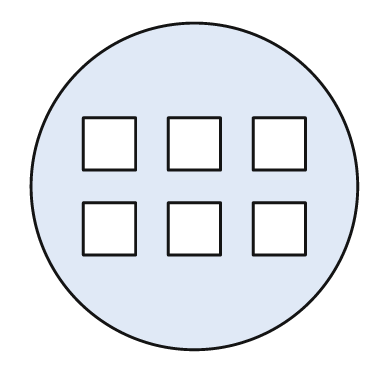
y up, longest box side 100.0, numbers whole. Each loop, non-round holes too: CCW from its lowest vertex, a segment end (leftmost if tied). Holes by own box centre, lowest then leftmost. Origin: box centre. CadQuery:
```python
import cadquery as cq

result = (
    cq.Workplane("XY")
    .moveTo(0.0, 0.0)
    .circle(50.0)
    .moveTo(-34.0, -21.0)
    .lineTo(-18.0, -21.0)
    .lineTo(-18.0, -5.0)
    .lineTo(-34.0, -5.0)
    .close()
    .moveTo(-8.0, -21.0)
    .lineTo(8.0, -21.0)
    .lineTo(8.0, -5.0)
    .lineTo(-8.0, -5.0)
    .close()
    .moveTo(18.0, -21.0)
    .lineTo(34.0, -21.0)
    .lineTo(34.0, -5.0)
    .lineTo(18.0, -5.0)
    .close()
    .moveTo(-34.0, 5.0)
    .lineTo(-18.0, 5.0)
    .lineTo(-18.0, 21.0)
    .lineTo(-34.0, 21.0)
    .close()
    .moveTo(-8.0, 5.0)
    .lineTo(8.0, 5.0)
    .lineTo(8.0, 21.0)
    .lineTo(-8.0, 21.0)
    .close()
    .moveTo(18.0, 5.0)
    .lineTo(34.0, 5.0)
    .lineTo(34.0, 21.0)
    .lineTo(18.0, 21.0)
    .close()
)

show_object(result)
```